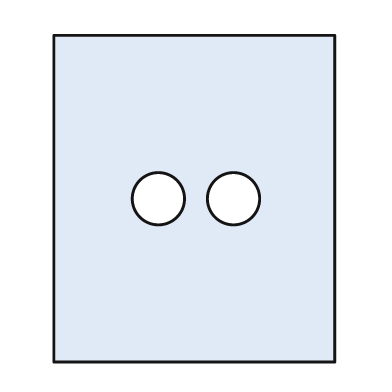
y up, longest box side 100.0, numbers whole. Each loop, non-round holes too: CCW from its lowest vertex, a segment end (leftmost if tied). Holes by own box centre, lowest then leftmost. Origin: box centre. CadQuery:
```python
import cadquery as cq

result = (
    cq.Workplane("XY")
    .moveTo(-43.0, -50.0)
    .lineTo(43.0, -50.0)
    .lineTo(43.0, 50.0)
    .lineTo(-43.0, 50.0)
    .close()
    .moveTo(-11.0, 0.0)
    .circle(8.0)
    .moveTo(12.0, 0.0)
    .circle(8.0)
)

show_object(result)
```